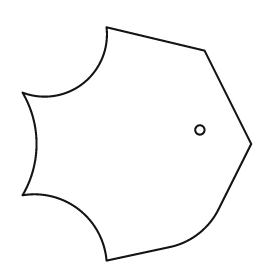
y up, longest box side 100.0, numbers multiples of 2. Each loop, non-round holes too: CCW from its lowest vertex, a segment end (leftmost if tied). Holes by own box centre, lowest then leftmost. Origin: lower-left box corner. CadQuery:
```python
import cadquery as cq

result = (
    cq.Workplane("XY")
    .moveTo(36.0, 0.0)
    .lineTo(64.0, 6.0)
    .threePointArc((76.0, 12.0), (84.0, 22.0))
    .lineTo(98.0, 50.0)
    .lineTo(78.0, 90.0)
    .lineTo(36.0, 100.0)
    .threePointArc((26.0, 76.0), (0.0, 72.0))
    .threePointArc((6.0, 50.0), (0.0, 28.0))
    .threePointArc((24.0, 22.0), (36.0, 0.0))
    .close()
    .moveTo(76.0, 56.0)
    .circle(2.0)
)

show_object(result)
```